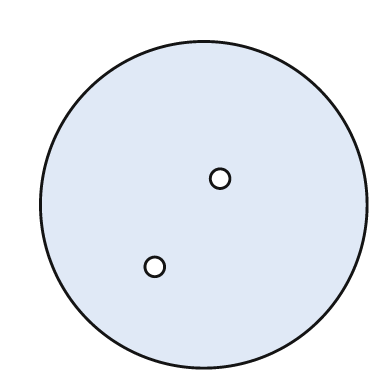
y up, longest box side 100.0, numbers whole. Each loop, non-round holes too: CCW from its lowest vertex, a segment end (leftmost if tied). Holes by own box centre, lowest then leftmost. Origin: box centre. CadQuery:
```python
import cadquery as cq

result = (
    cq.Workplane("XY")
    .moveTo(0.0, 0.0)
    .circle(50.0)
    .moveTo(-15.0, -19.0)
    .circle(3.0)
    .moveTo(5.0, 8.0)
    .circle(3.0)
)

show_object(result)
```